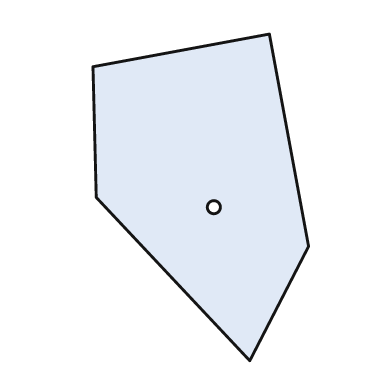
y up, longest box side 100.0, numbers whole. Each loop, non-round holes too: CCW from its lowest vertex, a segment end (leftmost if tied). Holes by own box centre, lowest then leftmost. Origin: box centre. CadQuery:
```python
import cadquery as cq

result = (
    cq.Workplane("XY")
    .moveTo(15.0, -50.0)
    .lineTo(33.0, -15.0)
    .lineTo(21.0, 50.0)
    .lineTo(-33.0, 40.0)
    .lineTo(-32.0, 0.0)
    .close()
    .moveTo(4.0, -3.0)
    .circle(2.0)
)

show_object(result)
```